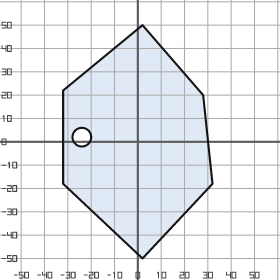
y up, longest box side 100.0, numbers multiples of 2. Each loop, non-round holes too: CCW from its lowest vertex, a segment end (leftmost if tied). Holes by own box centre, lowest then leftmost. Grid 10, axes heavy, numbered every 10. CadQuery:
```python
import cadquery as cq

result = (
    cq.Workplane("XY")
    .moveTo(2.0, -50.0)
    .lineTo(32.0, -18.0)
    .lineTo(28.0, 20.0)
    .lineTo(2.0, 50.0)
    .lineTo(-32.0, 22.0)
    .lineTo(-32.0, -18.0)
    .close()
    .moveTo(-24.0, 2.0)
    .circle(4.0)
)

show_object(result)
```